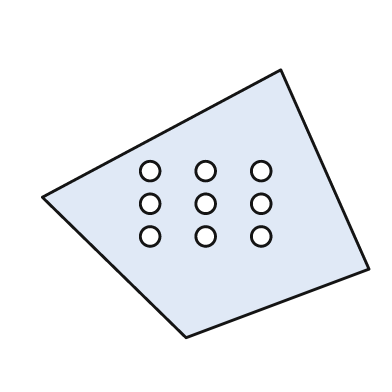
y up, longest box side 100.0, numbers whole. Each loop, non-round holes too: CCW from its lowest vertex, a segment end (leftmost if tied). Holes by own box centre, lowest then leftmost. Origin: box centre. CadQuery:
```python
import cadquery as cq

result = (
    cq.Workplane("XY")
    .moveTo(-6.0, -41.0)
    .lineTo(50.0, -20.0)
    .lineTo(23.0, 41.0)
    .lineTo(-50.0, 2.0)
    .close()
    .moveTo(-17.0, -10.0)
    .circle(3.0)
    .moveTo(0.0, -10.0)
    .circle(3.0)
    .moveTo(17.0, -10.0)
    .circle(3.0)
    .moveTo(-17.0, 0.0)
    .circle(3.0)
    .moveTo(0.0, 0.0)
    .circle(3.0)
    .moveTo(17.0, 0.0)
    .circle(3.0)
    .moveTo(-17.0, 10.0)
    .circle(3.0)
    .moveTo(0.0, 10.0)
    .circle(3.0)
    .moveTo(17.0, 10.0)
    .circle(3.0)
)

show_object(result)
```